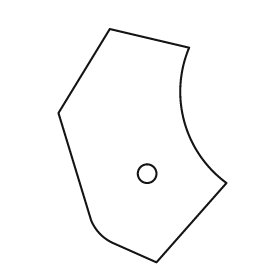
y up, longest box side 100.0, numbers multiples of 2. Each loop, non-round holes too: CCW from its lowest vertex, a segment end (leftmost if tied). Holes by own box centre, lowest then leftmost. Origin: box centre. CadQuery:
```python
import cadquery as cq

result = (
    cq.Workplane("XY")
    .moveTo(6.0, -50.0)
    .lineTo(36.0, -16.0)
    .threePointArc((18.0, 10.0), (20.0, 42.0))
    .lineTo(-14.0, 50.0)
    .lineTo(-36.0, 14.0)
    .lineTo(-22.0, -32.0)
    .threePointArc((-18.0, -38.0), (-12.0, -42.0))
    .close()
    .moveTo(2.0, -12.0)
    .circle(4.0)
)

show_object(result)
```